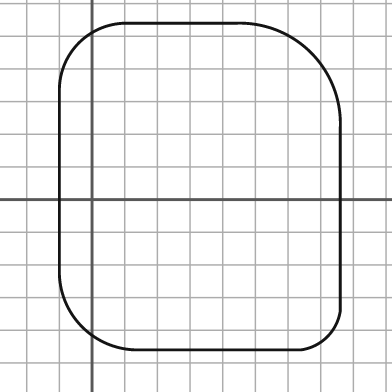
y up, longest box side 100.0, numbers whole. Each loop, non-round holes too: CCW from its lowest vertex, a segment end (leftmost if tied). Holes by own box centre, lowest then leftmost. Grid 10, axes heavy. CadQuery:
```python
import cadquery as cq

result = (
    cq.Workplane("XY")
    .moveTo(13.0, -46.0)
    .lineTo(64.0, -46.0)
    .threePointArc((72.0, -42.0), (76.0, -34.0))
    .lineTo(76.0, 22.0)
    .threePointArc((67.0, 45.0), (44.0, 54.0))
    .lineTo(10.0, 54.0)
    .threePointArc((-4.0, 48.0), (-10.0, 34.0))
    .lineTo(-10.0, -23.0)
    .threePointArc((-3.0, -39.0), (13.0, -46.0))
    .close()
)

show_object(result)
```